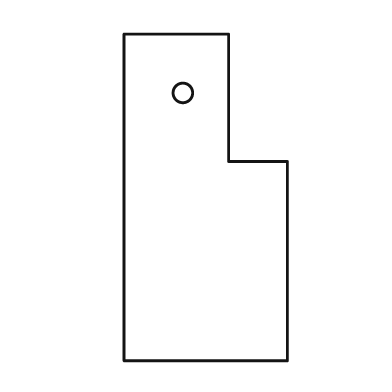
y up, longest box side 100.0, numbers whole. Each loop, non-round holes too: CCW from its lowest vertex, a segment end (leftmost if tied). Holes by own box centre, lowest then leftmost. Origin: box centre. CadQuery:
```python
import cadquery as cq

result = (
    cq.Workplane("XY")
    .moveTo(-25.0, -50.0)
    .lineTo(25.0, -50.0)
    .lineTo(25.0, 11.0)
    .lineTo(7.0, 11.0)
    .lineTo(7.0, 50.0)
    .lineTo(-25.0, 50.0)
    .close()
    .moveTo(-7.0, 32.0)
    .circle(3.0)
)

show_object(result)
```